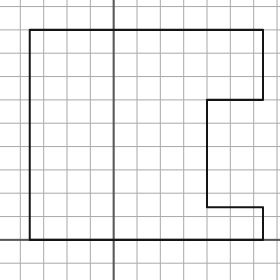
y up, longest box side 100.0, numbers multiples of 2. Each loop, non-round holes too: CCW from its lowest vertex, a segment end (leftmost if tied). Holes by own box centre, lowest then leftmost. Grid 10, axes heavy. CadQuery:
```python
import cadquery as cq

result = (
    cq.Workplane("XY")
    .moveTo(-36.0, 0.0)
    .lineTo(64.0, 0.0)
    .lineTo(64.0, 14.0)
    .lineTo(40.0, 14.0)
    .lineTo(40.0, 60.0)
    .lineTo(64.0, 60.0)
    .lineTo(64.0, 90.0)
    .lineTo(-36.0, 90.0)
    .close()
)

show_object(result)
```